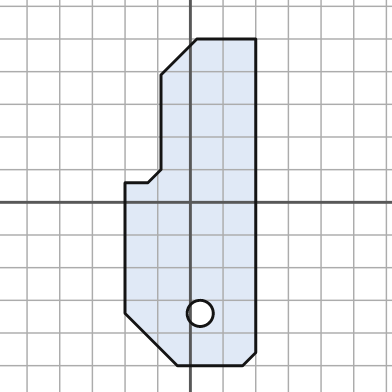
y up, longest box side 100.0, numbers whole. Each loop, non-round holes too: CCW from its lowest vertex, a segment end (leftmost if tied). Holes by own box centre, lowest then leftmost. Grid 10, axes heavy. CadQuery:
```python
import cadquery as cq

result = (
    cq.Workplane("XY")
    .moveTo(-4.0, -50.0)
    .lineTo(16.0, -50.0)
    .lineTo(20.0, -46.0)
    .lineTo(20.0, 50.0)
    .lineTo(2.0, 50.0)
    .lineTo(-9.0, 39.0)
    .lineTo(-9.0, 10.0)
    .lineTo(-13.0, 6.0)
    .lineTo(-20.0, 6.0)
    .lineTo(-20.0, -34.0)
    .close()
    .moveTo(3.0, -34.0)
    .circle(4.0)
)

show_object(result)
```